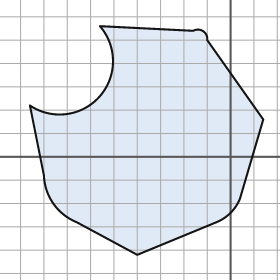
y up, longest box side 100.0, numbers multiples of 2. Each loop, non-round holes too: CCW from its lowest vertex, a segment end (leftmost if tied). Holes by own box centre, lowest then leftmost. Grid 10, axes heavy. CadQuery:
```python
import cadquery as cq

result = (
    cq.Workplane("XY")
    .moveTo(-40.0, -42.0)
    .lineTo(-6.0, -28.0)
    .threePointArc((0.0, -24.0), (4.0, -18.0))
    .lineTo(14.0, 16.0)
    .lineTo(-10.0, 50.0)
    .threePointArc((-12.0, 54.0), (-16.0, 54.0))
    .lineTo(-56.0, 56.0)
    .threePointArc((-56.0, 26.0), (-86.0, 22.0))
    .lineTo(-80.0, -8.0)
    .threePointArc((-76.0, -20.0), (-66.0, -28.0))
    .close()
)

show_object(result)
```